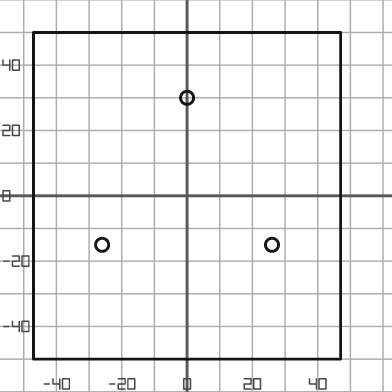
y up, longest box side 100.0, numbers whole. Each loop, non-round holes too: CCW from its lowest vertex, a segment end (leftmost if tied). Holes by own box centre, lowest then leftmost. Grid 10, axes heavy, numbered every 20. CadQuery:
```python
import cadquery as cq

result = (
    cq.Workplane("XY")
    .moveTo(-47.0, -50.0)
    .lineTo(47.0, -50.0)
    .lineTo(47.0, 50.0)
    .lineTo(-47.0, 50.0)
    .close()
    .moveTo(-26.0, -15.0)
    .circle(2.0)
    .moveTo(26.0, -15.0)
    .circle(2.0)
    .moveTo(0.0, 30.0)
    .circle(2.0)
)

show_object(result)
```